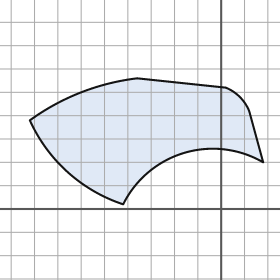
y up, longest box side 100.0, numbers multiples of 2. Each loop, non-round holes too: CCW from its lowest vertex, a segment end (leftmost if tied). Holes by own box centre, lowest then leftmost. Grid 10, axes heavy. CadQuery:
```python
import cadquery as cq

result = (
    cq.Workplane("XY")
    .moveTo(-42.0, 2.0)
    .threePointArc((-16.0, 24.0), (18.0, 20.0))
    .lineTo(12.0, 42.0)
    .threePointArc((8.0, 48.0), (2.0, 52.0))
    .lineTo(-36.0, 56.0)
    .threePointArc((-60.0, 50.0), (-82.0, 38.0))
    .threePointArc((-66.0, 16.0), (-42.0, 2.0))
    .close()
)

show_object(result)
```